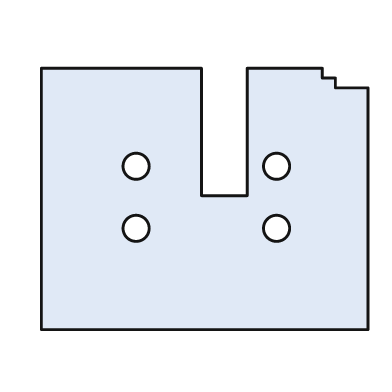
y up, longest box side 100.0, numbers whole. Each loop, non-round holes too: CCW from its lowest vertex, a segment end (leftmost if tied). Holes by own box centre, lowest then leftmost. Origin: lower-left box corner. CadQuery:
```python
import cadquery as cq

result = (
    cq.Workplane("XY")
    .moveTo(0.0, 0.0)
    .lineTo(100.0, 0.0)
    .lineTo(100.0, 74.0)
    .lineTo(90.0, 74.0)
    .lineTo(90.0, 77.0)
    .lineTo(86.0, 77.0)
    .lineTo(86.0, 80.0)
    .lineTo(63.0, 80.0)
    .lineTo(63.0, 41.0)
    .lineTo(49.0, 41.0)
    .lineTo(49.0, 80.0)
    .lineTo(0.0, 80.0)
    .close()
    .moveTo(29.0, 31.0)
    .circle(4.0)
    .moveTo(72.0, 31.0)
    .circle(4.0)
    .moveTo(29.0, 50.0)
    .circle(4.0)
    .moveTo(72.0, 50.0)
    .circle(4.0)
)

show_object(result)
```